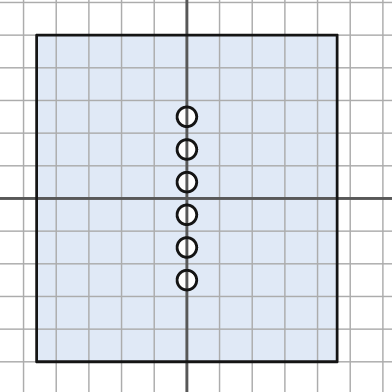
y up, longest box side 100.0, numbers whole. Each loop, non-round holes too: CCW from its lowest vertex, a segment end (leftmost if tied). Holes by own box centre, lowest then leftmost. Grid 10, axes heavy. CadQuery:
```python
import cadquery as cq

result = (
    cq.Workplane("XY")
    .moveTo(-46.0, -50.0)
    .lineTo(46.0, -50.0)
    .lineTo(46.0, 50.0)
    .lineTo(-46.0, 50.0)
    .close()
    .moveTo(0.0, -25.0)
    .circle(3.0)
    .moveTo(0.0, -15.0)
    .circle(3.0)
    .moveTo(0.0, -5.0)
    .circle(3.0)
    .moveTo(0.0, 5.0)
    .circle(3.0)
    .moveTo(0.0, 15.0)
    .circle(3.0)
    .moveTo(0.0, 25.0)
    .circle(3.0)
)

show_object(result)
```